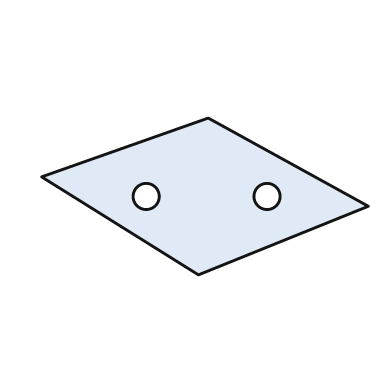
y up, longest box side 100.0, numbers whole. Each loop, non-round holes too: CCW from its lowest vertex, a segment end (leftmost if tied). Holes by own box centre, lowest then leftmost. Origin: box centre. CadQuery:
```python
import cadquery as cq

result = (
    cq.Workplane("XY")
    .moveTo(-2.0, -24.0)
    .lineTo(50.0, -3.0)
    .lineTo(1.0, 24.0)
    .lineTo(-50.0, 6.0)
    .close()
    .moveTo(-18.0, 0.0)
    .circle(4.0)
    .moveTo(19.0, 0.0)
    .circle(4.0)
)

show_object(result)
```